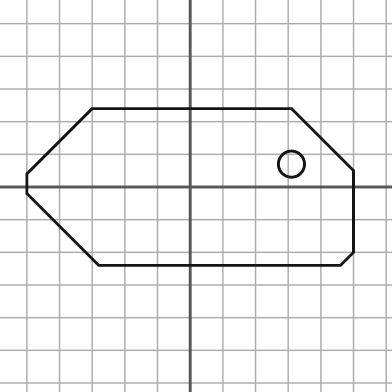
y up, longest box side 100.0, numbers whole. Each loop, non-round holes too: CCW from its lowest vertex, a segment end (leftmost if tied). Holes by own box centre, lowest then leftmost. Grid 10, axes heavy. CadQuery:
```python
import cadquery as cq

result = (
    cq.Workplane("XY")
    .moveTo(-28.0, -24.0)
    .lineTo(46.0, -24.0)
    .lineTo(50.0, -20.0)
    .lineTo(50.0, 5.0)
    .lineTo(31.0, 24.0)
    .lineTo(-30.0, 24.0)
    .lineTo(-50.0, 4.0)
    .lineTo(-50.0, -2.0)
    .close()
    .moveTo(31.0, 7.0)
    .circle(4.0)
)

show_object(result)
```